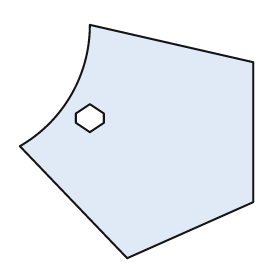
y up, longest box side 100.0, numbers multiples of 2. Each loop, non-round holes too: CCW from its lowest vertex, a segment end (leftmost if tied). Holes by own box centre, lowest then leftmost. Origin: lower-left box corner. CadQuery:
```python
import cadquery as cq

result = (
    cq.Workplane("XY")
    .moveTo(46.0, 0.0)
    .lineTo(100.0, 24.0)
    .lineTo(100.0, 84.0)
    .lineTo(30.0, 100.0)
    .threePointArc((22.0, 70.0), (0.0, 48.0))
    .close()
    .moveTo(30.0, 54.0)
    .lineTo(36.0, 58.0)
    .lineTo(36.0, 62.0)
    .lineTo(30.0, 66.0)
    .lineTo(24.0, 62.0)
    .lineTo(24.0, 58.0)
    .close()
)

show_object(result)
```